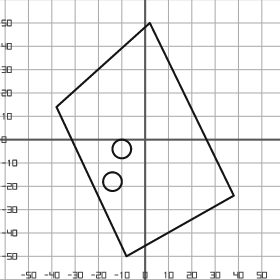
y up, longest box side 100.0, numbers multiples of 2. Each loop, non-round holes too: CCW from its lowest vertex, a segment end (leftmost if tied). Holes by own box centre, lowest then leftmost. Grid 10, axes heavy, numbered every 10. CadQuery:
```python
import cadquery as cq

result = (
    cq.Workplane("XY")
    .moveTo(-8.0, -50.0)
    .lineTo(38.0, -24.0)
    .lineTo(2.0, 50.0)
    .lineTo(-38.0, 14.0)
    .close()
    .moveTo(-14.0, -18.0)
    .circle(4.0)
    .moveTo(-10.0, -4.0)
    .circle(4.0)
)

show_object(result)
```